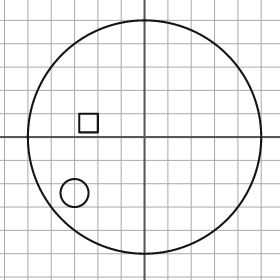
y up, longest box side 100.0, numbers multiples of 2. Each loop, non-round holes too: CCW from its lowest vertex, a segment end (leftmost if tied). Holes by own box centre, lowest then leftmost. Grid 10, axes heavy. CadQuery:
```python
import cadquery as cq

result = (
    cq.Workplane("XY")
    .moveTo(0.0, 0.0)
    .circle(50.0)
    .moveTo(-30.0, -24.0)
    .circle(6.0)
    .moveTo(-28.0, 2.0)
    .lineTo(-20.0, 2.0)
    .lineTo(-20.0, 10.0)
    .lineTo(-28.0, 10.0)
    .close()
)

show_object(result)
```